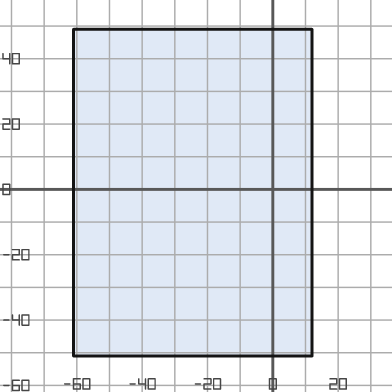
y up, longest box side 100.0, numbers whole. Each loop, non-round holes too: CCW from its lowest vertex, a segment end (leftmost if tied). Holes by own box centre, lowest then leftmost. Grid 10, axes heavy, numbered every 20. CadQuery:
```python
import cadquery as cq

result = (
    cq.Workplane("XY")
    .moveTo(-61.0, -51.0)
    .lineTo(12.0, -51.0)
    .lineTo(12.0, 49.0)
    .lineTo(-61.0, 49.0)
    .close()
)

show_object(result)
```